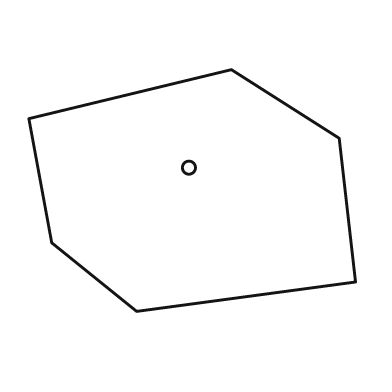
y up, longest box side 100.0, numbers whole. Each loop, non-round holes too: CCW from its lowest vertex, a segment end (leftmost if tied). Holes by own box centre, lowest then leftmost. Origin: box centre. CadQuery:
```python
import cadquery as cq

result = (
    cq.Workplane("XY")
    .moveTo(-17.0, -37.0)
    .lineTo(50.0, -28.0)
    .lineTo(45.0, 16.0)
    .lineTo(12.0, 37.0)
    .lineTo(-50.0, 22.0)
    .lineTo(-43.0, -16.0)
    .close()
    .moveTo(-1.0, 7.0)
    .circle(2.0)
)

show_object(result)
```